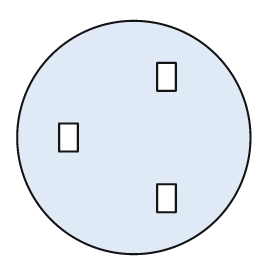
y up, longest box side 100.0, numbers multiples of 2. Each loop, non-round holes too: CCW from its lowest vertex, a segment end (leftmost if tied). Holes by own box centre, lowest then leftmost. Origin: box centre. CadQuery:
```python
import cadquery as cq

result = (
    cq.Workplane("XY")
    .moveTo(0.0, 0.0)
    .circle(50.0)
    .moveTo(10.0, -32.0)
    .lineTo(18.0, -32.0)
    .lineTo(18.0, -20.0)
    .lineTo(10.0, -20.0)
    .close()
    .moveTo(-32.0, -6.0)
    .lineTo(-24.0, -6.0)
    .lineTo(-24.0, 6.0)
    .lineTo(-32.0, 6.0)
    .close()
    .moveTo(10.0, 20.0)
    .lineTo(18.0, 20.0)
    .lineTo(18.0, 32.0)
    .lineTo(10.0, 32.0)
    .close()
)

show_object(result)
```